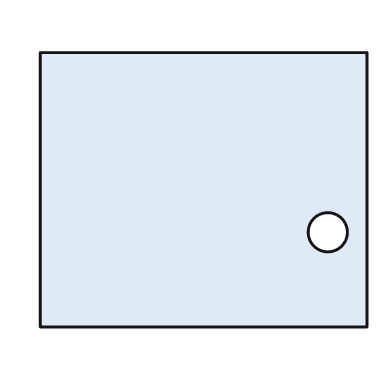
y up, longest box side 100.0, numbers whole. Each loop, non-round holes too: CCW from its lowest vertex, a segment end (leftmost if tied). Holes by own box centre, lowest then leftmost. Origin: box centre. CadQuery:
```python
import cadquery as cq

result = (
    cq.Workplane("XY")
    .moveTo(-50.0, -42.0)
    .lineTo(50.0, -42.0)
    .lineTo(50.0, 42.0)
    .lineTo(-50.0, 42.0)
    .close()
    .moveTo(38.0, -13.0)
    .circle(6.0)
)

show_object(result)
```